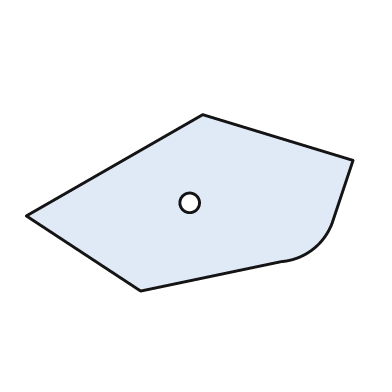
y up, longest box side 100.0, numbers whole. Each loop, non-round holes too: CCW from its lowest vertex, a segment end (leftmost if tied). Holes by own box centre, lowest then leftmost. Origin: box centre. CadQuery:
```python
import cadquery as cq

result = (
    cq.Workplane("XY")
    .moveTo(-15.0, -27.0)
    .lineTo(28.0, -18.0)
    .threePointArc((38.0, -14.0), (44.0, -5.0))
    .lineTo(50.0, 13.0)
    .lineTo(4.0, 27.0)
    .lineTo(-50.0, -4.0)
    .close()
    .moveTo(0.0, 0.0)
    .circle(3.0)
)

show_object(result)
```